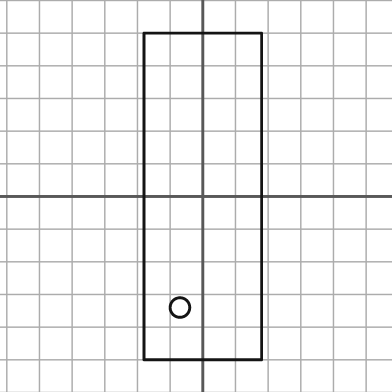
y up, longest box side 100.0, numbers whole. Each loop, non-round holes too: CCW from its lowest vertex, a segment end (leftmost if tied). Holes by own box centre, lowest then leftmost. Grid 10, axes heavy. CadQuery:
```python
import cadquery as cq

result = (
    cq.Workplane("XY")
    .moveTo(-18.0, -50.0)
    .lineTo(18.0, -50.0)
    .lineTo(18.0, 50.0)
    .lineTo(-18.0, 50.0)
    .close()
    .moveTo(-7.0, -34.0)
    .circle(3.0)
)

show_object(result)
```